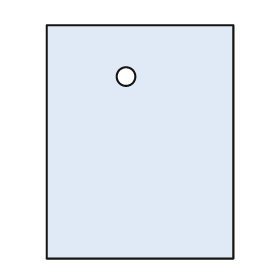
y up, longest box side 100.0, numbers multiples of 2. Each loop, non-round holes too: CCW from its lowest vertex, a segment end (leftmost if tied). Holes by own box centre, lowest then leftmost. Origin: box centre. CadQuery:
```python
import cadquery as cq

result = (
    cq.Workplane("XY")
    .moveTo(-40.0, -50.0)
    .lineTo(40.0, -50.0)
    .lineTo(40.0, 50.0)
    .lineTo(-40.0, 50.0)
    .close()
    .moveTo(-6.0, 28.0)
    .circle(4.0)
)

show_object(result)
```